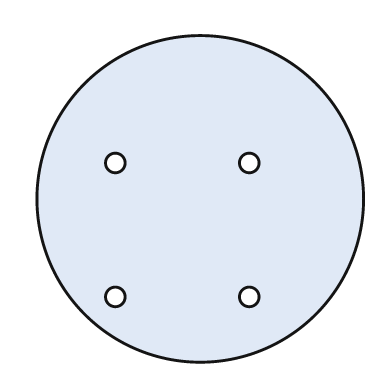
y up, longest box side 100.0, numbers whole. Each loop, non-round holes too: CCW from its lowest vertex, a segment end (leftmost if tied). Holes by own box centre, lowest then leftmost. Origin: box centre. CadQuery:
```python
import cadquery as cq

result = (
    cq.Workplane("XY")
    .moveTo(0.0, 0.0)
    .circle(50.0)
    .moveTo(-26.0, -30.0)
    .circle(3.0)
    .moveTo(15.0, -30.0)
    .circle(3.0)
    .moveTo(-26.0, 11.0)
    .circle(3.0)
    .moveTo(15.0, 11.0)
    .circle(3.0)
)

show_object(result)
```